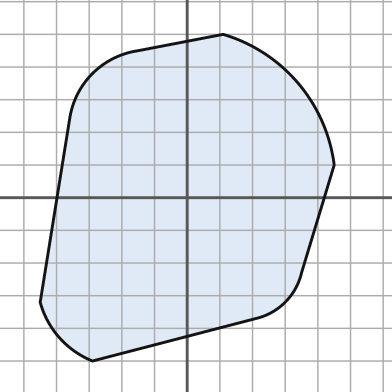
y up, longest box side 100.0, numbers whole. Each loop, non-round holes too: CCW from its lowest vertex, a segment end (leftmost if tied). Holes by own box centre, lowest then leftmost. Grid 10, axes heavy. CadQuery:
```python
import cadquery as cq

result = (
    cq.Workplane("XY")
    .moveTo(-29.0, -50.0)
    .lineTo(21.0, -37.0)
    .threePointArc((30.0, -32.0), (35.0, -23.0))
    .lineTo(45.0, 10.0)
    .threePointArc((34.0, 35.0), (11.0, 50.0))
    .lineTo(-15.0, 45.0)
    .threePointArc((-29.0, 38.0), (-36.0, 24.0))
    .lineTo(-45.0, -32.0)
    .threePointArc((-39.0, -43.0), (-29.0, -50.0))
    .close()
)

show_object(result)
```